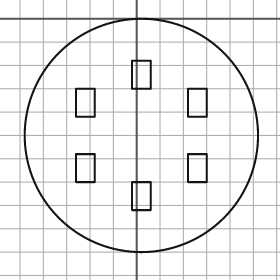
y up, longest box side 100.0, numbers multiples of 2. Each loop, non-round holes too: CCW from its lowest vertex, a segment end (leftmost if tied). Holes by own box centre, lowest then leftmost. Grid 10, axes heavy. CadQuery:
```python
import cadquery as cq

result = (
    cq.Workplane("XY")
    .moveTo(2.0, -50.0)
    .circle(50.0)
    .moveTo(-2.0, -82.0)
    .lineTo(6.0, -82.0)
    .lineTo(6.0, -70.0)
    .lineTo(-2.0, -70.0)
    .close()
    .moveTo(-26.0, -70.0)
    .lineTo(-18.0, -70.0)
    .lineTo(-18.0, -58.0)
    .lineTo(-26.0, -58.0)
    .close()
    .moveTo(22.0, -70.0)
    .lineTo(30.0, -70.0)
    .lineTo(30.0, -58.0)
    .lineTo(22.0, -58.0)
    .close()
    .moveTo(-26.0, -42.0)
    .lineTo(-18.0, -42.0)
    .lineTo(-18.0, -30.0)
    .lineTo(-26.0, -30.0)
    .close()
    .moveTo(22.0, -42.0)
    .lineTo(30.0, -42.0)
    .lineTo(30.0, -30.0)
    .lineTo(22.0, -30.0)
    .close()
    .moveTo(-2.0, -30.0)
    .lineTo(6.0, -30.0)
    .lineTo(6.0, -18.0)
    .lineTo(-2.0, -18.0)
    .close()
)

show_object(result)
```